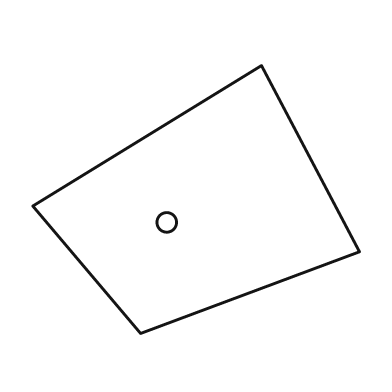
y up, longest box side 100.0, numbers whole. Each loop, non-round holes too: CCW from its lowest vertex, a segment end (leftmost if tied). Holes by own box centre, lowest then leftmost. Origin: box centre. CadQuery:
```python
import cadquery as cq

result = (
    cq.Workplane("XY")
    .moveTo(-17.0, -41.0)
    .lineTo(50.0, -16.0)
    .lineTo(20.0, 41.0)
    .lineTo(-50.0, -2.0)
    .close()
    .moveTo(-9.0, -7.0)
    .circle(3.0)
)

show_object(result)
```